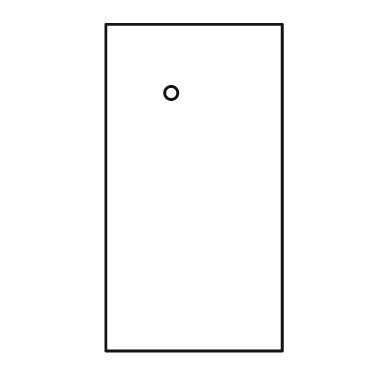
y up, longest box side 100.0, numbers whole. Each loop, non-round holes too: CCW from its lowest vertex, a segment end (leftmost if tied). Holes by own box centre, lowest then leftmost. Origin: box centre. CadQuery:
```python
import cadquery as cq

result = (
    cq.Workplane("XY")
    .moveTo(-27.0, -50.0)
    .lineTo(27.0, -50.0)
    .lineTo(27.0, 50.0)
    .lineTo(-27.0, 50.0)
    .close()
    .moveTo(-7.0, 29.0)
    .circle(2.0)
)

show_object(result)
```